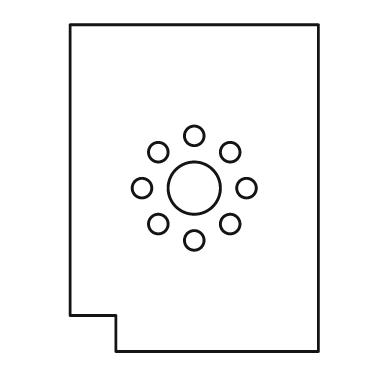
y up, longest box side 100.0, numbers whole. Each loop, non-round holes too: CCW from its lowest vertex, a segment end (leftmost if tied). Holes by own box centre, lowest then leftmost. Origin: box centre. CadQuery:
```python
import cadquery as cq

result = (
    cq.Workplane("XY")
    .moveTo(-24.0, -50.0)
    .lineTo(38.0, -50.0)
    .lineTo(38.0, 50.0)
    .lineTo(-38.0, 50.0)
    .lineTo(-38.0, -39.0)
    .lineTo(-24.0, -39.0)
    .close()
    .moveTo(0.0, -16.0)
    .circle(3.0)
    .moveTo(-11.0, -11.0)
    .circle(3.0)
    .moveTo(11.0, -11.0)
    .circle(3.0)
    .moveTo(-16.0, 0.0)
    .circle(3.0)
    .moveTo(0.0, 0.0)
    .circle(8.0)
    .moveTo(16.0, 0.0)
    .circle(3.0)
    .moveTo(-11.0, 11.0)
    .circle(3.0)
    .moveTo(11.0, 11.0)
    .circle(3.0)
    .moveTo(0.0, 16.0)
    .circle(3.0)
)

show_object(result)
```